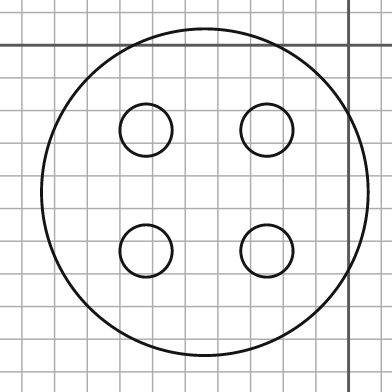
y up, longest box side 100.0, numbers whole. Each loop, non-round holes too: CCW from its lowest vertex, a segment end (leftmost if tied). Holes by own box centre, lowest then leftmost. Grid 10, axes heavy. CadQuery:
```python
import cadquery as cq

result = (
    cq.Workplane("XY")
    .moveTo(-44.0, -45.0)
    .circle(50.0)
    .moveTo(-62.0, -63.0)
    .circle(8.0)
    .moveTo(-25.0, -63.0)
    .circle(8.0)
    .moveTo(-62.0, -26.0)
    .circle(8.0)
    .moveTo(-25.0, -26.0)
    .circle(8.0)
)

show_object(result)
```